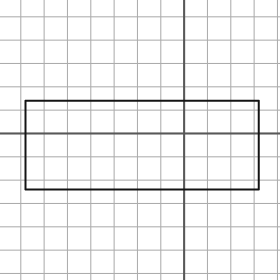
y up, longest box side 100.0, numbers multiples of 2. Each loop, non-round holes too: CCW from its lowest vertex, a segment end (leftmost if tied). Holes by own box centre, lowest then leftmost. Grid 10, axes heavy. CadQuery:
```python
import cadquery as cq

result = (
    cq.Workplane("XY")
    .moveTo(-68.0, -24.0)
    .lineTo(32.0, -24.0)
    .lineTo(32.0, 14.0)
    .lineTo(-68.0, 14.0)
    .close()
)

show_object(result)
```